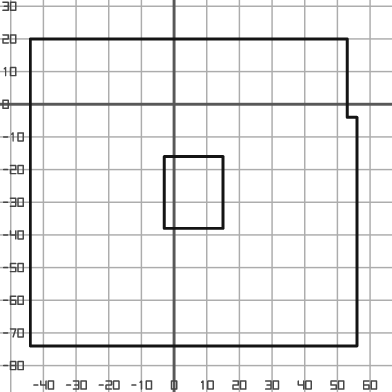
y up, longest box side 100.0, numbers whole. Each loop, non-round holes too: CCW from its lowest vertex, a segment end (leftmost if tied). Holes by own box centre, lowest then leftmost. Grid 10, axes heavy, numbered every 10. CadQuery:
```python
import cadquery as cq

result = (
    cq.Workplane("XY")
    .moveTo(-44.0, -74.0)
    .lineTo(56.0, -74.0)
    .lineTo(56.0, -4.0)
    .lineTo(53.0, -4.0)
    .lineTo(53.0, 20.0)
    .lineTo(-44.0, 20.0)
    .close()
    .moveTo(-3.0, -38.0)
    .lineTo(15.0, -38.0)
    .lineTo(15.0, -16.0)
    .lineTo(-3.0, -16.0)
    .close()
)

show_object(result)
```